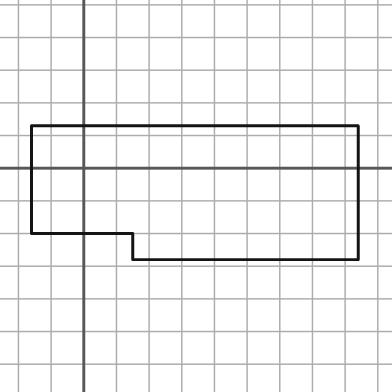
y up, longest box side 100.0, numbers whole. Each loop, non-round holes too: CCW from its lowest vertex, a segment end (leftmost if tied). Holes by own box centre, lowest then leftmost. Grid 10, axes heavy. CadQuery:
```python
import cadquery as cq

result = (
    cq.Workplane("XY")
    .moveTo(15.0, -28.0)
    .lineTo(84.0, -28.0)
    .lineTo(84.0, 13.0)
    .lineTo(-16.0, 13.0)
    .lineTo(-16.0, -20.0)
    .lineTo(15.0, -20.0)
    .close()
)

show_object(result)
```